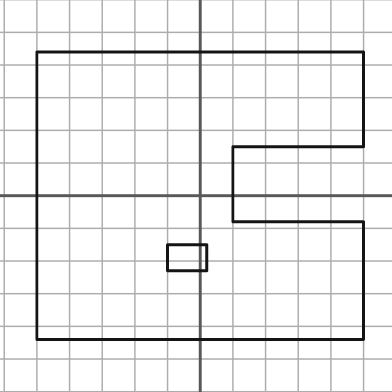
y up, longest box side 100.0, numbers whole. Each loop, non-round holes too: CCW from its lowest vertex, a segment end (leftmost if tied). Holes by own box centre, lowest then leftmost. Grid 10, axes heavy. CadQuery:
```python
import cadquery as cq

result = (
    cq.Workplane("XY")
    .moveTo(-50.0, -44.0)
    .lineTo(50.0, -44.0)
    .lineTo(50.0, -8.0)
    .lineTo(10.0, -8.0)
    .lineTo(10.0, 15.0)
    .lineTo(50.0, 15.0)
    .lineTo(50.0, 44.0)
    .lineTo(-50.0, 44.0)
    .close()
    .moveTo(-10.0, -23.0)
    .lineTo(2.0, -23.0)
    .lineTo(2.0, -15.0)
    .lineTo(-10.0, -15.0)
    .close()
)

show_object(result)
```